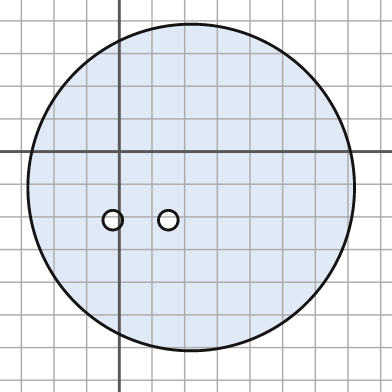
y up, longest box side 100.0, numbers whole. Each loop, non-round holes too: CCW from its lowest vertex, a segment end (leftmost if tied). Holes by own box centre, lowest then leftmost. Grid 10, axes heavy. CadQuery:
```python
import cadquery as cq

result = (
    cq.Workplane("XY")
    .moveTo(22.0, -11.0)
    .circle(50.0)
    .moveTo(-2.0, -21.0)
    .circle(3.0)
    .moveTo(15.0, -21.0)
    .circle(3.0)
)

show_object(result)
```